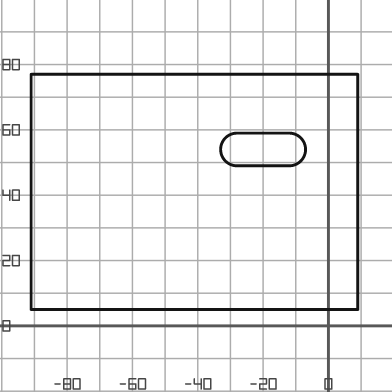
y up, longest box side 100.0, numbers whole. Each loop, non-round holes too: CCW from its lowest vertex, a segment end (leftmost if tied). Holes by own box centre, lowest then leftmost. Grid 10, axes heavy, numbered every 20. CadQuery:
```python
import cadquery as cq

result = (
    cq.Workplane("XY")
    .moveTo(-91.0, 5.0)
    .lineTo(9.0, 5.0)
    .lineTo(9.0, 77.0)
    .lineTo(-91.0, 77.0)
    .close()
    .moveTo(-28.0, 49.0)
    .lineTo(-12.0, 49.0)
    .threePointArc((-7.0, 54.0), (-12.0, 59.0))
    .lineTo(-28.0, 59.0)
    .threePointArc((-33.0, 54.0), (-28.0, 49.0))
    .close()
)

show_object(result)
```